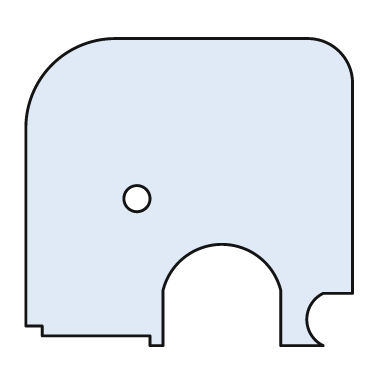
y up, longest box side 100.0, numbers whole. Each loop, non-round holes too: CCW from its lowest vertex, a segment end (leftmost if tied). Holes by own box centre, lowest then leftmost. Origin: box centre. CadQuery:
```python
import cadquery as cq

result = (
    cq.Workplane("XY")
    .moveTo(-12.0, -47.0)
    .lineTo(-8.0, -47.0)
    .lineTo(-8.0, -30.0)
    .threePointArc((10.0, -16.0), (28.0, -30.0))
    .lineTo(28.0, -47.0)
    .lineTo(41.0, -47.0)
    .threePointArc((36.0, -39.0), (41.0, -31.0))
    .lineTo(50.0, -31.0)
    .lineTo(50.0, 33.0)
    .threePointArc((46.0, 43.0), (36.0, 47.0))
    .lineTo(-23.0, 47.0)
    .threePointArc((-42.0, 39.0), (-50.0, 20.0))
    .lineTo(-50.0, -41.0)
    .lineTo(-45.0, -41.0)
    .lineTo(-45.0, -44.0)
    .lineTo(-12.0, -44.0)
    .close()
    .moveTo(-16.0, -2.0)
    .circle(4.0)
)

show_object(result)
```